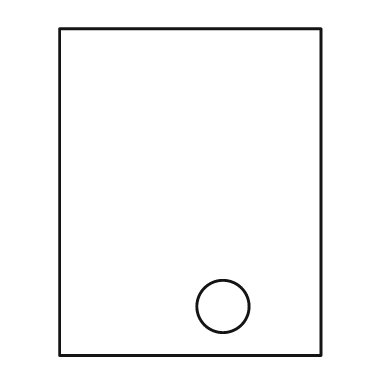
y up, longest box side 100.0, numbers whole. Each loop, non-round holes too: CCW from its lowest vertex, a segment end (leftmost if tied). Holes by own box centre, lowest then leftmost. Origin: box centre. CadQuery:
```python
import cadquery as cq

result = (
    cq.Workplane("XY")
    .moveTo(-40.0, -50.0)
    .lineTo(40.0, -50.0)
    .lineTo(40.0, 50.0)
    .lineTo(-40.0, 50.0)
    .close()
    .moveTo(10.0, -35.0)
    .circle(8.0)
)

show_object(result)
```